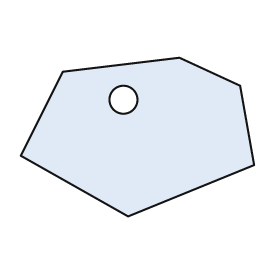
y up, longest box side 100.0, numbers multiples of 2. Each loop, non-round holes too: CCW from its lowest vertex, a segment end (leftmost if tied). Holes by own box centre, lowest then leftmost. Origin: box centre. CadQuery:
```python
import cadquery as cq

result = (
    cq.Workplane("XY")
    .moveTo(-4.0, -34.0)
    .lineTo(50.0, -12.0)
    .lineTo(44.0, 22.0)
    .lineTo(18.0, 34.0)
    .lineTo(-32.0, 28.0)
    .lineTo(-50.0, -8.0)
    .close()
    .moveTo(-6.0, 16.0)
    .circle(6.0)
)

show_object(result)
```